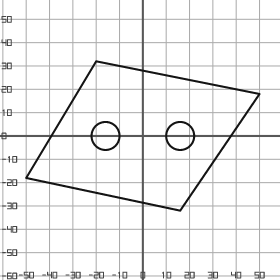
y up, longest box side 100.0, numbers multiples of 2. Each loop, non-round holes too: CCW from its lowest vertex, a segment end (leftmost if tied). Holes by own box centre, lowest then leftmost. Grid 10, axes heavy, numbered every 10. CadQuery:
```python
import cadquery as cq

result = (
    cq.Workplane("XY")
    .moveTo(16.0, -32.0)
    .lineTo(50.0, 18.0)
    .lineTo(-20.0, 32.0)
    .lineTo(-50.0, -18.0)
    .close()
    .moveTo(-16.0, 0.0)
    .circle(6.0)
    .moveTo(16.0, 0.0)
    .circle(6.0)
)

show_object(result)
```